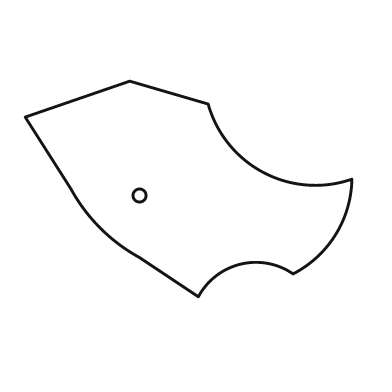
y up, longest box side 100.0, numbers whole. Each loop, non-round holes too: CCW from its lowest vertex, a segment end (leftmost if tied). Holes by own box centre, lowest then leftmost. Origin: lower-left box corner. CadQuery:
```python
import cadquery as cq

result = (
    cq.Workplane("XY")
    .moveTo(53.0, 0.0)
    .threePointArc((66.0, 10.0), (82.0, 7.0))
    .threePointArc((95.0, 19.0), (100.0, 36.0))
    .threePointArc((73.0, 38.0), (56.0, 59.0))
    .lineTo(32.0, 66.0)
    .lineTo(0.0, 55.0)
    .lineTo(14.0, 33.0)
    .threePointArc((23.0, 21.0), (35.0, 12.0))
    .close()
    .moveTo(35.0, 31.0)
    .circle(2.0)
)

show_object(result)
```